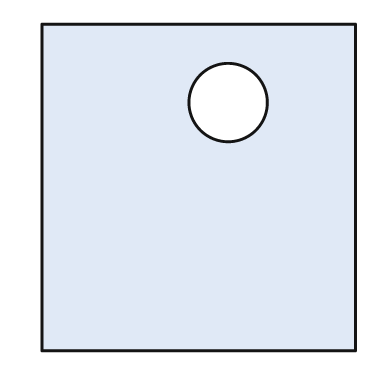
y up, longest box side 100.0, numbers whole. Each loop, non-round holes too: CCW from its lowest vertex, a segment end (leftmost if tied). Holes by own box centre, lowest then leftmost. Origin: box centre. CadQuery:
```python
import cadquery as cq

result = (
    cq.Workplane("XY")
    .moveTo(-48.0, -50.0)
    .lineTo(48.0, -50.0)
    .lineTo(48.0, 50.0)
    .lineTo(-48.0, 50.0)
    .close()
    .moveTo(9.0, 26.0)
    .circle(12.0)
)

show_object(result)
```